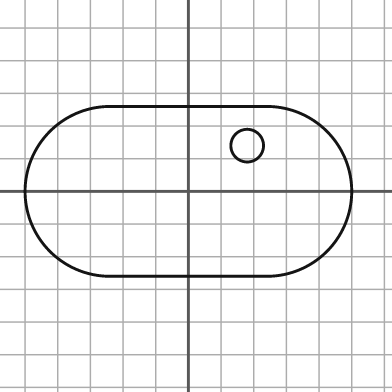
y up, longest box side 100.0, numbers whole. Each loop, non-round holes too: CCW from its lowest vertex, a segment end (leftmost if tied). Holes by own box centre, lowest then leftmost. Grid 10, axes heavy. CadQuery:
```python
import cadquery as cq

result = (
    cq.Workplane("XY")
    .moveTo(-24.0, -26.0)
    .lineTo(24.0, -26.0)
    .threePointArc((50.0, 0.0), (24.0, 26.0))
    .lineTo(-24.0, 26.0)
    .threePointArc((-50.0, 0.0), (-24.0, -26.0))
    .close()
    .moveTo(18.0, 14.0)
    .circle(5.0)
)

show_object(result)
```